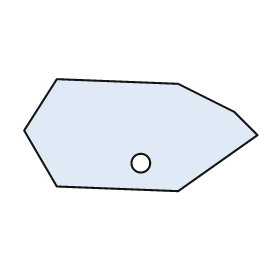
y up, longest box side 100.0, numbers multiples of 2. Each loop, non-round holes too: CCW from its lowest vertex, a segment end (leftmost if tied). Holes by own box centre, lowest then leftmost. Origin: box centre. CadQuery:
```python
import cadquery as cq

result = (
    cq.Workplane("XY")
    .moveTo(16.0, -24.0)
    .lineTo(50.0, 0.0)
    .lineTo(40.0, 10.0)
    .lineTo(16.0, 22.0)
    .lineTo(-36.0, 24.0)
    .lineTo(-50.0, 2.0)
    .lineTo(-36.0, -22.0)
    .close()
    .moveTo(0.0, -12.0)
    .circle(4.0)
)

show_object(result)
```